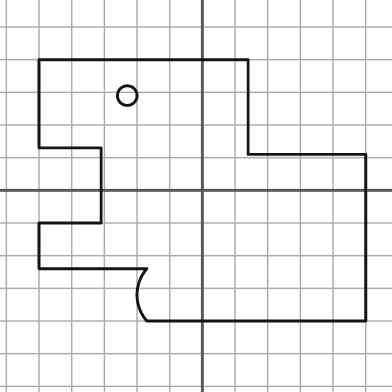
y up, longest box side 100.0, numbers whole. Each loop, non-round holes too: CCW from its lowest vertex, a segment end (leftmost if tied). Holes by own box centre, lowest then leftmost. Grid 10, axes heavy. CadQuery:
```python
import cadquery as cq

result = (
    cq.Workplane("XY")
    .moveTo(-17.0, -40.0)
    .lineTo(50.0, -40.0)
    .lineTo(50.0, 11.0)
    .lineTo(14.0, 11.0)
    .lineTo(14.0, 40.0)
    .lineTo(-50.0, 40.0)
    .lineTo(-50.0, 13.0)
    .lineTo(-31.0, 13.0)
    .lineTo(-31.0, -10.0)
    .lineTo(-50.0, -10.0)
    .lineTo(-50.0, -24.0)
    .lineTo(-17.0, -24.0)
    .threePointArc((-20.0, -32.0), (-17.0, -40.0))
    .close()
    .moveTo(-23.0, 29.0)
    .circle(3.0)
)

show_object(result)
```